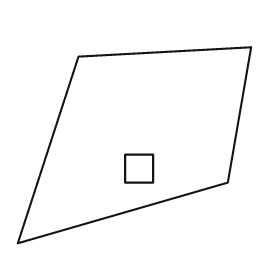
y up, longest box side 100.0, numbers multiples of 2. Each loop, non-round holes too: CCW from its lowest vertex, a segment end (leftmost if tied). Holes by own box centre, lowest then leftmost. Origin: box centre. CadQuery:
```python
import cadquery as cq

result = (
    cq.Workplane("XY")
    .moveTo(-50.0, -42.0)
    .lineTo(40.0, -16.0)
    .lineTo(50.0, 42.0)
    .lineTo(-24.0, 38.0)
    .close()
    .moveTo(-4.0, -16.0)
    .lineTo(8.0, -16.0)
    .lineTo(8.0, -4.0)
    .lineTo(-4.0, -4.0)
    .close()
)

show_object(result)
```